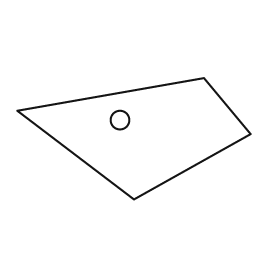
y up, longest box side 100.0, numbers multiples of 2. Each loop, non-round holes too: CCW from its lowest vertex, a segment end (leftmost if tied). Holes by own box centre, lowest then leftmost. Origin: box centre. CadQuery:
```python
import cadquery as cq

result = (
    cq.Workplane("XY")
    .moveTo(0.0, -26.0)
    .lineTo(50.0, 2.0)
    .lineTo(30.0, 26.0)
    .lineTo(-50.0, 12.0)
    .close()
    .moveTo(-6.0, 8.0)
    .circle(4.0)
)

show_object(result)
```